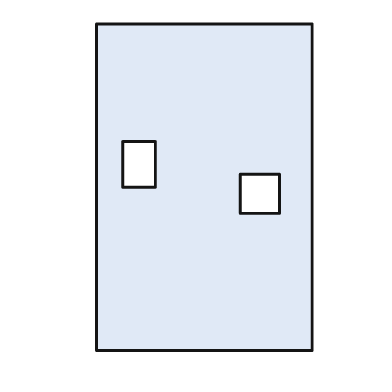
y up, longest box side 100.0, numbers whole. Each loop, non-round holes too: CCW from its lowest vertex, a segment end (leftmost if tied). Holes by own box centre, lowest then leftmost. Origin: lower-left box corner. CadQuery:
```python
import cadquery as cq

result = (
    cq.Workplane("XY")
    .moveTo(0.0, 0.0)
    .lineTo(66.0, 0.0)
    .lineTo(66.0, 100.0)
    .lineTo(0.0, 100.0)
    .close()
    .moveTo(44.0, 42.0)
    .lineTo(56.0, 42.0)
    .lineTo(56.0, 54.0)
    .lineTo(44.0, 54.0)
    .close()
    .moveTo(8.0, 50.0)
    .lineTo(18.0, 50.0)
    .lineTo(18.0, 64.0)
    .lineTo(8.0, 64.0)
    .close()
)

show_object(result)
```